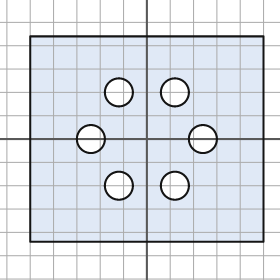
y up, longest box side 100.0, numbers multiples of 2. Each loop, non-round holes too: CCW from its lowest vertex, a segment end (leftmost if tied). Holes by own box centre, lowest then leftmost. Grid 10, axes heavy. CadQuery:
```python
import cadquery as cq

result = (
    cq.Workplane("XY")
    .moveTo(-50.0, -44.0)
    .lineTo(50.0, -44.0)
    .lineTo(50.0, 44.0)
    .lineTo(-50.0, 44.0)
    .close()
    .moveTo(-12.0, -20.0)
    .circle(6.0)
    .moveTo(12.0, -20.0)
    .circle(6.0)
    .moveTo(-24.0, 0.0)
    .circle(6.0)
    .moveTo(24.0, 0.0)
    .circle(6.0)
    .moveTo(-12.0, 20.0)
    .circle(6.0)
    .moveTo(12.0, 20.0)
    .circle(6.0)
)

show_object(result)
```